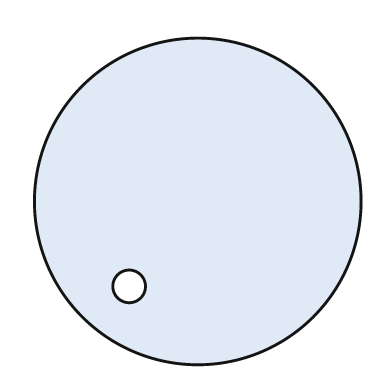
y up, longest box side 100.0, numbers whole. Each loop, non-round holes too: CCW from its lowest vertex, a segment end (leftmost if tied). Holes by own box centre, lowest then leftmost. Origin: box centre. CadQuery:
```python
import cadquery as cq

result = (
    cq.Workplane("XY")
    .moveTo(0.0, 0.0)
    .circle(50.0)
    .moveTo(-21.0, -26.0)
    .circle(5.0)
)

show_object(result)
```